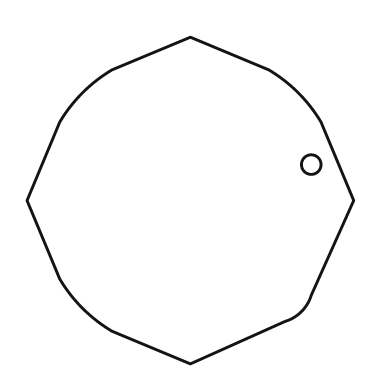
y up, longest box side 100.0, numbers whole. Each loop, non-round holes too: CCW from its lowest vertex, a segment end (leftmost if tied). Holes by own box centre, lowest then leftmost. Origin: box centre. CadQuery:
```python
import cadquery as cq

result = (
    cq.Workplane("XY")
    .moveTo(0.0, -50.0)
    .lineTo(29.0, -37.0)
    .threePointArc((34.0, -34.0), (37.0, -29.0))
    .lineTo(50.0, 0.0)
    .lineTo(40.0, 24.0)
    .threePointArc((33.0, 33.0), (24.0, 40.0))
    .lineTo(0.0, 50.0)
    .lineTo(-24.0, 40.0)
    .threePointArc((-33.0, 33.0), (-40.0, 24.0))
    .lineTo(-50.0, 0.0)
    .lineTo(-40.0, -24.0)
    .threePointArc((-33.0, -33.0), (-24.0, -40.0))
    .close()
    .moveTo(37.0, 11.0)
    .circle(3.0)
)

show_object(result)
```